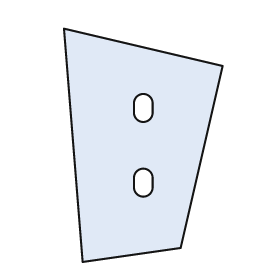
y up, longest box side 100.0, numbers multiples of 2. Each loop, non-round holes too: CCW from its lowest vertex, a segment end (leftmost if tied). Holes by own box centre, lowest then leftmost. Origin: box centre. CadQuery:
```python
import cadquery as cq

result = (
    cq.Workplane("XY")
    .moveTo(-26.0, -50.0)
    .lineTo(16.0, -44.0)
    .lineTo(34.0, 34.0)
    .lineTo(-34.0, 50.0)
    .close()
    .moveTo(-4.0, -18.0)
    .threePointArc((0.0, -22.0), (4.0, -18.0))
    .lineTo(4.0, -14.0)
    .threePointArc((0.0, -10.0), (-4.0, -14.0))
    .close()
    .moveTo(-4.0, 14.0)
    .threePointArc((0.0, 10.0), (4.0, 14.0))
    .lineTo(4.0, 18.0)
    .threePointArc((0.0, 22.0), (-4.0, 18.0))
    .close()
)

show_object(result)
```